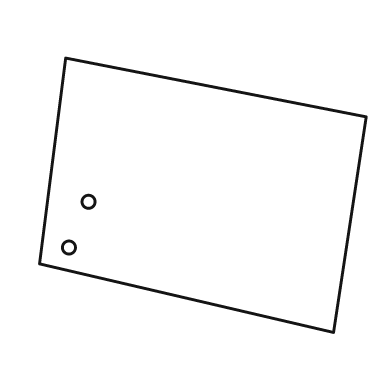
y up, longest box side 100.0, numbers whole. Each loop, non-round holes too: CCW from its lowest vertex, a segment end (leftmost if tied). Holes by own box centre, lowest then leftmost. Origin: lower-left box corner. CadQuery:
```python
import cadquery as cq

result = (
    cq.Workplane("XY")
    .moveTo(90.0, 0.0)
    .lineTo(100.0, 66.0)
    .lineTo(8.0, 84.0)
    .lineTo(0.0, 21.0)
    .close()
    .moveTo(9.0, 26.0)
    .circle(2.0)
    .moveTo(15.0, 40.0)
    .circle(2.0)
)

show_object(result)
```